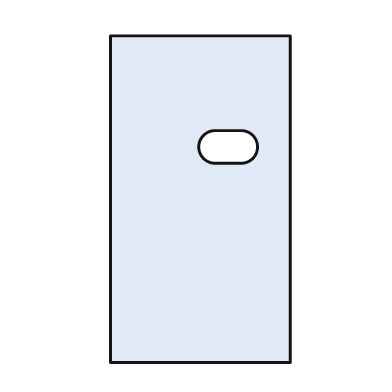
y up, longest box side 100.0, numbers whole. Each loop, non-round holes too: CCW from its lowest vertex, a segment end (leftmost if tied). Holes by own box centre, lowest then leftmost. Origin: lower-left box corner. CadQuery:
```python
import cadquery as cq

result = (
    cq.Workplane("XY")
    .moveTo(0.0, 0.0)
    .lineTo(55.0, 0.0)
    .lineTo(55.0, 100.0)
    .lineTo(0.0, 100.0)
    .close()
    .moveTo(32.0, 61.0)
    .lineTo(40.0, 61.0)
    .threePointArc((45.0, 66.0), (40.0, 71.0))
    .lineTo(32.0, 71.0)
    .threePointArc((27.0, 66.0), (32.0, 61.0))
    .close()
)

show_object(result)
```